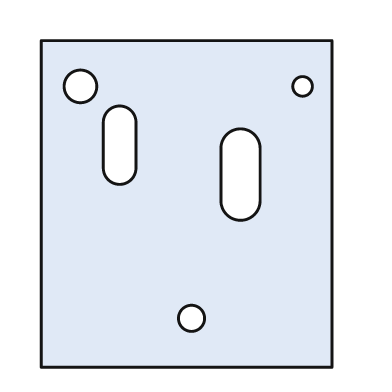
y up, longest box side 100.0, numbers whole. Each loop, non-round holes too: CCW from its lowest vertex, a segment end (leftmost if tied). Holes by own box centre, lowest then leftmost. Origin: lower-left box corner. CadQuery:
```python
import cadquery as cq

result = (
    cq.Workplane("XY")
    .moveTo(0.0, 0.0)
    .lineTo(89.0, 0.0)
    .lineTo(89.0, 100.0)
    .lineTo(0.0, 100.0)
    .close()
    .moveTo(46.0, 15.0)
    .circle(4.0)
    .moveTo(55.0, 51.0)
    .threePointArc((61.0, 45.0), (67.0, 51.0))
    .lineTo(67.0, 67.0)
    .threePointArc((61.0, 73.0), (55.0, 67.0))
    .close()
    .moveTo(19.0, 61.0)
    .threePointArc((24.0, 56.0), (29.0, 61.0))
    .lineTo(29.0, 75.0)
    .threePointArc((24.0, 80.0), (19.0, 75.0))
    .close()
    .moveTo(12.0, 86.0)
    .circle(5.0)
    .moveTo(80.0, 86.0)
    .circle(3.0)
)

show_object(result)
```